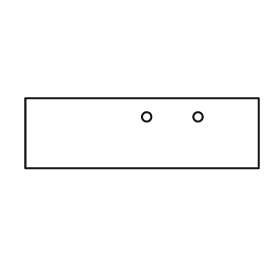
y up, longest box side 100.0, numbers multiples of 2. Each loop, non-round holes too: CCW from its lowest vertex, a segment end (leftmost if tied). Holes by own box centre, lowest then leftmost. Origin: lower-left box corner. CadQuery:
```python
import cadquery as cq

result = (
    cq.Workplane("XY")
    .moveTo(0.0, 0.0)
    .lineTo(100.0, 0.0)
    .lineTo(100.0, 30.0)
    .lineTo(0.0, 30.0)
    .close()
    .moveTo(52.0, 22.0)
    .circle(2.0)
    .moveTo(74.0, 22.0)
    .circle(2.0)
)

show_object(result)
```